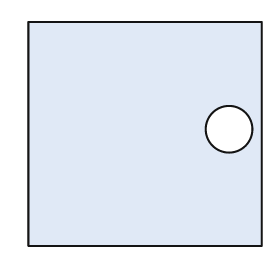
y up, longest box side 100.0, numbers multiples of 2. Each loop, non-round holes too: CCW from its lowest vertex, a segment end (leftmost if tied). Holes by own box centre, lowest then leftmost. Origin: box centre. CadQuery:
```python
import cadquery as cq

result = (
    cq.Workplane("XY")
    .moveTo(-50.0, -48.0)
    .lineTo(50.0, -48.0)
    .lineTo(50.0, 48.0)
    .lineTo(-50.0, 48.0)
    .close()
    .moveTo(36.0, 2.0)
    .circle(10.0)
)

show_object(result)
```